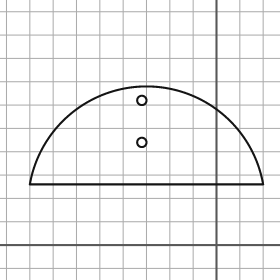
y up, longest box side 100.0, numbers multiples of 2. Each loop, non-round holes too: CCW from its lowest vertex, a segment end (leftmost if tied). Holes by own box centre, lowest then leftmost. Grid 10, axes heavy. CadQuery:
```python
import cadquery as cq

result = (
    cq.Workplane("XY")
    .moveTo(-80.0, 26.0)
    .lineTo(20.0, 26.0)
    .threePointArc((-30.0, 68.0), (-80.0, 26.0))
    .close()
    .moveTo(-32.0, 44.0)
    .circle(2.0)
    .moveTo(-32.0, 62.0)
    .circle(2.0)
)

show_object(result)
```